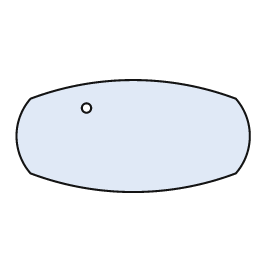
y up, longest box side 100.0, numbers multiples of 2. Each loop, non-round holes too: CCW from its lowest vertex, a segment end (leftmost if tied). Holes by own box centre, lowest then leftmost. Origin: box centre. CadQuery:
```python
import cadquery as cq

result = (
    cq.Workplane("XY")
    .moveTo(-44.0, -16.0)
    .threePointArc((0.0, -24.0), (44.0, -16.0))
    .threePointArc((50.0, 0.0), (44.0, 16.0))
    .threePointArc((0.0, 24.0), (-44.0, 16.0))
    .threePointArc((-50.0, 0.0), (-44.0, -16.0))
    .close()
    .moveTo(-20.0, 12.0)
    .circle(2.0)
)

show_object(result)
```